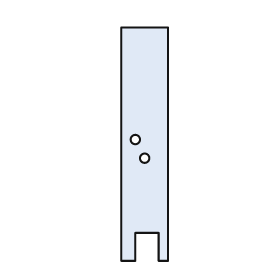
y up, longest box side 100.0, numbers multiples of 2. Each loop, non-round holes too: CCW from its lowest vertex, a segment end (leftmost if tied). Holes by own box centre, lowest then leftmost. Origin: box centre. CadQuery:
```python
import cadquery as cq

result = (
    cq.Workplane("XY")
    .moveTo(-10.0, -50.0)
    .lineTo(-4.0, -50.0)
    .lineTo(-4.0, -38.0)
    .lineTo(6.0, -38.0)
    .lineTo(6.0, -50.0)
    .lineTo(10.0, -50.0)
    .lineTo(10.0, 50.0)
    .lineTo(-10.0, 50.0)
    .close()
    .moveTo(0.0, -6.0)
    .circle(2.0)
    .moveTo(-4.0, 2.0)
    .circle(2.0)
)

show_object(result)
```